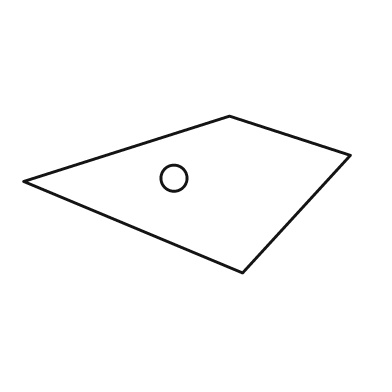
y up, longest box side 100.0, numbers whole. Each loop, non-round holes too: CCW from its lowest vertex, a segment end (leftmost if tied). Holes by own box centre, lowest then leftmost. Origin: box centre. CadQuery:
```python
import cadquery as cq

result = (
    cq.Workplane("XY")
    .moveTo(17.0, -24.0)
    .lineTo(50.0, 12.0)
    .lineTo(13.0, 24.0)
    .lineTo(-50.0, 4.0)
    .close()
    .moveTo(-4.0, 5.0)
    .circle(4.0)
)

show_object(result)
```